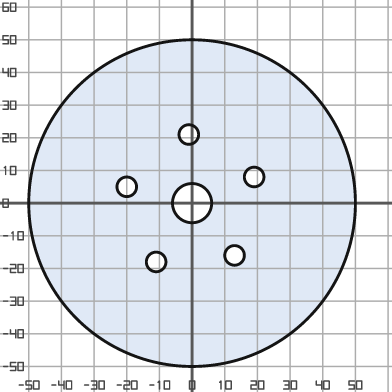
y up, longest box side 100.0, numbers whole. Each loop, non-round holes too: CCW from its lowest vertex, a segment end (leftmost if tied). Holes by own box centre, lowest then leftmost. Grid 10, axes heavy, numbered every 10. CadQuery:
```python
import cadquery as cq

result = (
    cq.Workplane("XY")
    .moveTo(0.0, 0.0)
    .circle(50.0)
    .moveTo(-11.0, -18.0)
    .circle(3.0)
    .moveTo(13.0, -16.0)
    .circle(3.0)
    .moveTo(0.0, 0.0)
    .circle(6.0)
    .moveTo(-20.0, 5.0)
    .circle(3.0)
    .moveTo(19.0, 8.0)
    .circle(3.0)
    .moveTo(-1.0, 21.0)
    .circle(3.0)
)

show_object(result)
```